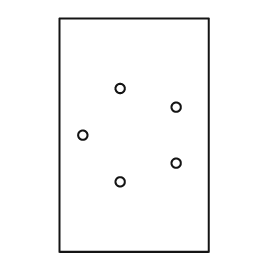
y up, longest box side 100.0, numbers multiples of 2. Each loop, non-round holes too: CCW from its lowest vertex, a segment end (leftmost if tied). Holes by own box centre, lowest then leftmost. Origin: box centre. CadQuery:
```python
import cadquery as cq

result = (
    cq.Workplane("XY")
    .moveTo(-32.0, -50.0)
    .lineTo(32.0, -50.0)
    .lineTo(32.0, 50.0)
    .lineTo(-32.0, 50.0)
    .close()
    .moveTo(-6.0, -20.0)
    .circle(2.0)
    .moveTo(18.0, -12.0)
    .circle(2.0)
    .moveTo(-22.0, 0.0)
    .circle(2.0)
    .moveTo(18.0, 12.0)
    .circle(2.0)
    .moveTo(-6.0, 20.0)
    .circle(2.0)
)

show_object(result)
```